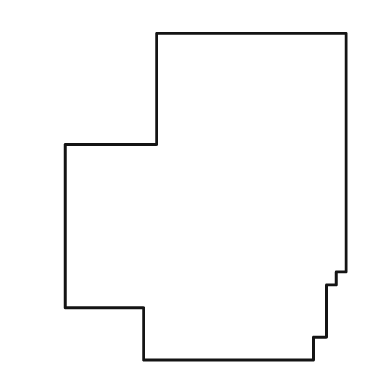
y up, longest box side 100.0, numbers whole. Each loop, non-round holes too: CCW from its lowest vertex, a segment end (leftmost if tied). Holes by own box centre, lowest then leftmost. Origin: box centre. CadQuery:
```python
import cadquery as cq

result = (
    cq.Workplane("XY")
    .moveTo(-19.0, -50.0)
    .lineTo(33.0, -50.0)
    .lineTo(33.0, -43.0)
    .lineTo(37.0, -43.0)
    .lineTo(37.0, -27.0)
    .lineTo(40.0, -27.0)
    .lineTo(40.0, -23.0)
    .lineTo(43.0, -23.0)
    .lineTo(43.0, 50.0)
    .lineTo(-15.0, 50.0)
    .lineTo(-15.0, 16.0)
    .lineTo(-43.0, 16.0)
    .lineTo(-43.0, -34.0)
    .lineTo(-19.0, -34.0)
    .close()
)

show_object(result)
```